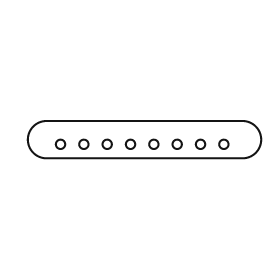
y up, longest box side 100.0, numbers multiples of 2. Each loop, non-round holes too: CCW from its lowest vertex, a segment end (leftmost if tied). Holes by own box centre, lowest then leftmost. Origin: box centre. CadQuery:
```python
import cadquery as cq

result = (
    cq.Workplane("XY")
    .moveTo(-42.0, -8.0)
    .lineTo(42.0, -8.0)
    .threePointArc((50.0, 0.0), (42.0, 8.0))
    .lineTo(-42.0, 8.0)
    .threePointArc((-50.0, 0.0), (-42.0, -8.0))
    .close()
    .moveTo(-36.0, -2.0)
    .circle(2.0)
    .moveTo(-26.0, -2.0)
    .circle(2.0)
    .moveTo(-16.0, -2.0)
    .circle(2.0)
    .moveTo(-6.0, -2.0)
    .circle(2.0)
    .moveTo(4.0, -2.0)
    .circle(2.0)
    .moveTo(14.0, -2.0)
    .circle(2.0)
    .moveTo(24.0, -2.0)
    .circle(2.0)
    .moveTo(34.0, -2.0)
    .circle(2.0)
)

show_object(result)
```